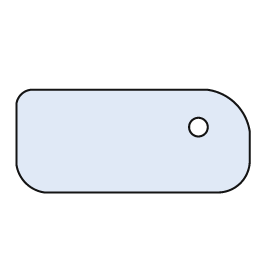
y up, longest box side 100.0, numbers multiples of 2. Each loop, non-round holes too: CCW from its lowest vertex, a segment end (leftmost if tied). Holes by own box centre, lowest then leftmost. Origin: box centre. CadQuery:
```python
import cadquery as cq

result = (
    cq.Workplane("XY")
    .moveTo(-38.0, -22.0)
    .lineTo(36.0, -22.0)
    .threePointArc((46.0, -18.0), (50.0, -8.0))
    .lineTo(50.0, 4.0)
    .threePointArc((44.0, 16.0), (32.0, 22.0))
    .lineTo(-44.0, 22.0)
    .threePointArc((-48.0, 20.0), (-50.0, 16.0))
    .lineTo(-50.0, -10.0)
    .threePointArc((-46.0, -18.0), (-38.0, -22.0))
    .close()
    .moveTo(28.0, 6.0)
    .circle(4.0)
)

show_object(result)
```